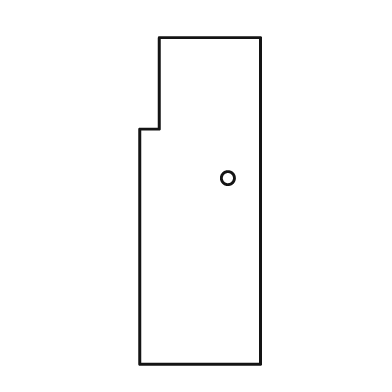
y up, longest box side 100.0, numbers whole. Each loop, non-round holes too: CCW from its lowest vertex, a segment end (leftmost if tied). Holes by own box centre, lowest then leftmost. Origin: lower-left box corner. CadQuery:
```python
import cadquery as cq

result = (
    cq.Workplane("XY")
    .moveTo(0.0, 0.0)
    .lineTo(37.0, 0.0)
    .lineTo(37.0, 100.0)
    .lineTo(6.0, 100.0)
    .lineTo(6.0, 72.0)
    .lineTo(0.0, 72.0)
    .close()
    .moveTo(27.0, 57.0)
    .circle(2.0)
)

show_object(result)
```